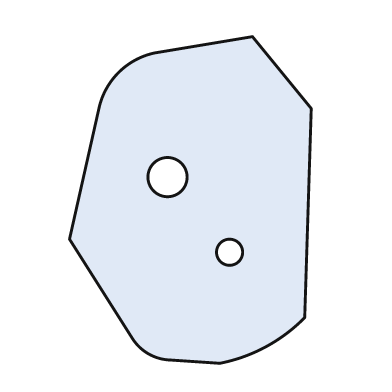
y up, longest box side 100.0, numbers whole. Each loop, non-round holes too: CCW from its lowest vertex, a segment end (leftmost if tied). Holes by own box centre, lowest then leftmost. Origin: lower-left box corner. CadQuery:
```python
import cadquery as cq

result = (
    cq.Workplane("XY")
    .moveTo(46.0, 0.0)
    .threePointArc((60.0, 5.0), (72.0, 14.0))
    .lineTo(74.0, 78.0)
    .lineTo(56.0, 100.0)
    .lineTo(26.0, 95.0)
    .threePointArc((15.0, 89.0), (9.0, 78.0))
    .lineTo(0.0, 38.0)
    .lineTo(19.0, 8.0)
    .threePointArc((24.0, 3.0), (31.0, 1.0))
    .close()
    .moveTo(49.0, 34.0)
    .circle(4.0)
    .moveTo(30.0, 57.0)
    .circle(6.0)
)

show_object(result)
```